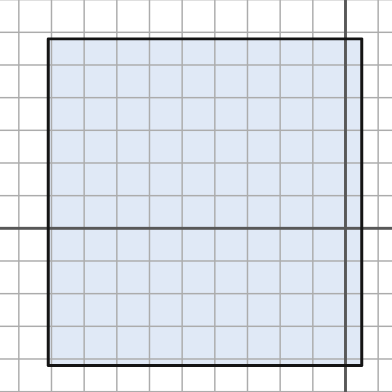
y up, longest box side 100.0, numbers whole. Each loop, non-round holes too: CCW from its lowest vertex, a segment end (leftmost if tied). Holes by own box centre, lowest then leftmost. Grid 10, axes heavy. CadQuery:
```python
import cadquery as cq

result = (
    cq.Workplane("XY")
    .moveTo(-91.0, -42.0)
    .lineTo(5.0, -42.0)
    .lineTo(5.0, 58.0)
    .lineTo(-91.0, 58.0)
    .close()
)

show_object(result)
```